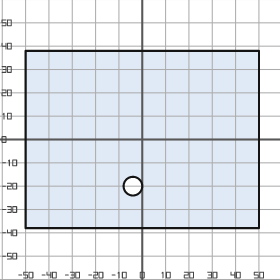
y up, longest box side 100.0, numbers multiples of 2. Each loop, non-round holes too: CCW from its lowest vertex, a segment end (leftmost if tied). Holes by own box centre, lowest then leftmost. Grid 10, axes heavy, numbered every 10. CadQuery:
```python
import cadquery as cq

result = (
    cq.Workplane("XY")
    .moveTo(-50.0, -38.0)
    .lineTo(50.0, -38.0)
    .lineTo(50.0, 38.0)
    .lineTo(-50.0, 38.0)
    .close()
    .moveTo(-4.0, -20.0)
    .circle(4.0)
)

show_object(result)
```